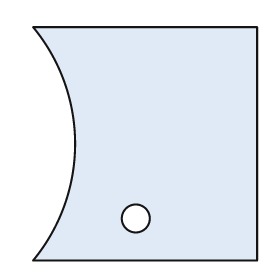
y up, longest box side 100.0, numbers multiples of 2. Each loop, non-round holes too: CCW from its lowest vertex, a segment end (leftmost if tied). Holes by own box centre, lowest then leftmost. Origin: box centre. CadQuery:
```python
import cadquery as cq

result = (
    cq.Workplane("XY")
    .moveTo(-48.0, -50.0)
    .lineTo(48.0, -50.0)
    .lineTo(48.0, 50.0)
    .lineTo(-48.0, 50.0)
    .threePointArc((-30.0, 0.0), (-48.0, -50.0))
    .close()
    .moveTo(-4.0, -32.0)
    .circle(6.0)
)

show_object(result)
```